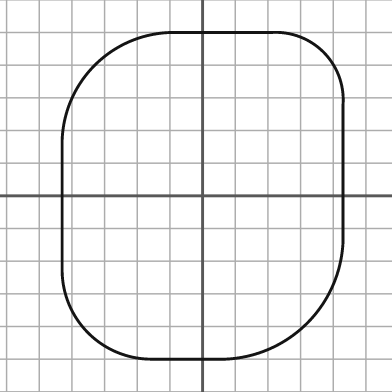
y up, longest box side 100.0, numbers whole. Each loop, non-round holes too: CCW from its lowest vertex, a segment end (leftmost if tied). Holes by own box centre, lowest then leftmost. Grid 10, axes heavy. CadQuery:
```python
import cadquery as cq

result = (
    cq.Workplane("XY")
    .moveTo(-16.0, -50.0)
    .lineTo(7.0, -50.0)
    .threePointArc((32.0, -39.0), (43.0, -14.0))
    .lineTo(43.0, 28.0)
    .threePointArc((37.0, 44.0), (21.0, 50.0))
    .lineTo(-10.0, 50.0)
    .threePointArc((-33.0, 40.0), (-43.0, 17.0))
    .lineTo(-43.0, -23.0)
    .threePointArc((-35.0, -42.0), (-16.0, -50.0))
    .close()
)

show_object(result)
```